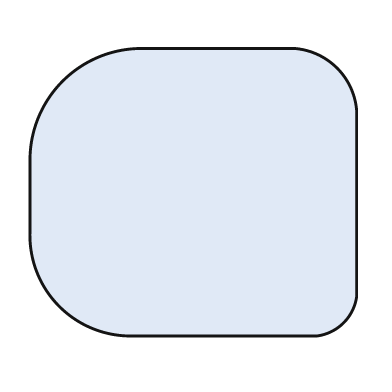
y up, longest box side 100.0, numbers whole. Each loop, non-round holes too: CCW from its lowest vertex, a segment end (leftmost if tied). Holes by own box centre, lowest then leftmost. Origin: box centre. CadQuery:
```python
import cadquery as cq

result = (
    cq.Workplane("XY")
    .moveTo(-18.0, -44.0)
    .lineTo(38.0, -44.0)
    .threePointArc((46.0, -40.0), (50.0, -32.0))
    .lineTo(50.0, 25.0)
    .threePointArc((44.0, 38.0), (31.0, 44.0))
    .lineTo(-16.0, 44.0)
    .threePointArc((-40.0, 34.0), (-50.0, 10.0))
    .lineTo(-50.0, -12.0)
    .threePointArc((-41.0, -35.0), (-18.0, -44.0))
    .close()
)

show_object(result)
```